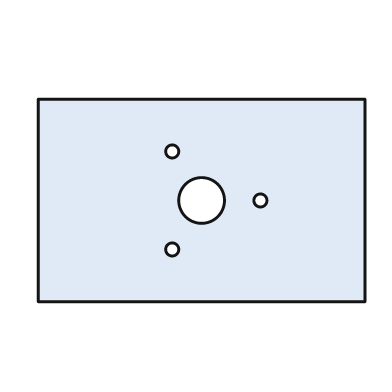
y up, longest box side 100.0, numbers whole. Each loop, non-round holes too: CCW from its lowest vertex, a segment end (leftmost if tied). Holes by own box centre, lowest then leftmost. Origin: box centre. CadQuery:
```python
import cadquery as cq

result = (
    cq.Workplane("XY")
    .moveTo(-50.0, -31.0)
    .lineTo(50.0, -31.0)
    .lineTo(50.0, 31.0)
    .lineTo(-50.0, 31.0)
    .close()
    .moveTo(-9.0, -15.0)
    .circle(2.0)
    .moveTo(0.0, 0.0)
    .circle(7.0)
    .moveTo(18.0, 0.0)
    .circle(2.0)
    .moveTo(-9.0, 15.0)
    .circle(2.0)
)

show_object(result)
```